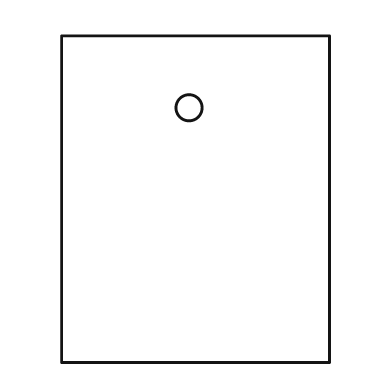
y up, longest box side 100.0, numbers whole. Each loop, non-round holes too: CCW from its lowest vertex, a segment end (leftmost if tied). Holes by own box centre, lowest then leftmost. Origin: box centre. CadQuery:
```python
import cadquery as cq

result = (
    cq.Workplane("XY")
    .moveTo(-41.0, -50.0)
    .lineTo(41.0, -50.0)
    .lineTo(41.0, 50.0)
    .lineTo(-41.0, 50.0)
    .close()
    .moveTo(-2.0, 28.0)
    .circle(4.0)
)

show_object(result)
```